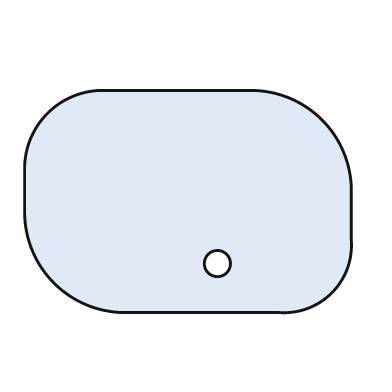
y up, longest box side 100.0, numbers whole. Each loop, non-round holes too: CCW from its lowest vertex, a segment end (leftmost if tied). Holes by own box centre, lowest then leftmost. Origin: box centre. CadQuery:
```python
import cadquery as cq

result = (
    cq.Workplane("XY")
    .moveTo(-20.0, -34.0)
    .lineTo(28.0, -34.0)
    .threePointArc((44.0, -28.0), (50.0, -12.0))
    .lineTo(50.0, 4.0)
    .threePointArc((41.0, 25.0), (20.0, 34.0))
    .lineTo(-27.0, 34.0)
    .threePointArc((-43.0, 27.0), (-50.0, 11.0))
    .lineTo(-50.0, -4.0)
    .threePointArc((-41.0, -25.0), (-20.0, -34.0))
    .close()
    .moveTo(9.0, -19.0)
    .circle(4.0)
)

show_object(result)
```